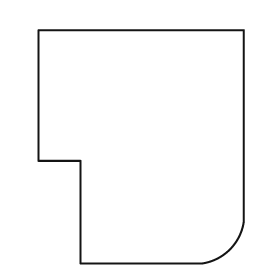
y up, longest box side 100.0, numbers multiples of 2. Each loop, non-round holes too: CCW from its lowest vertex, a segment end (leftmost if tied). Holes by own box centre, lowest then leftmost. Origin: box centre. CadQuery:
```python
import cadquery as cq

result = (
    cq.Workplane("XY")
    .moveTo(-26.0, -50.0)
    .lineTo(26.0, -50.0)
    .threePointArc((38.0, -44.0), (44.0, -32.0))
    .lineTo(44.0, 50.0)
    .lineTo(-44.0, 50.0)
    .lineTo(-44.0, -6.0)
    .lineTo(-26.0, -6.0)
    .close()
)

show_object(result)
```